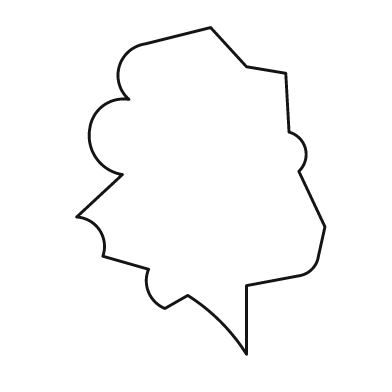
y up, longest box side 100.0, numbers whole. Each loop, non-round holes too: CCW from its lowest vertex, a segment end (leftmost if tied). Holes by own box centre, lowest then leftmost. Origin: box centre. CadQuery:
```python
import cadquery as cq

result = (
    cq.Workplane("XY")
    .moveTo(14.0, -50.0)
    .lineTo(14.0, -29.0)
    .lineTo(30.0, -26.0)
    .threePointArc((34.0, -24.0), (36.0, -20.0))
    .lineTo(38.0, -11.0)
    .lineTo(30.0, 6.0)
    .threePointArc((32.0, 13.0), (27.0, 18.0))
    .lineTo(26.0, 36.0)
    .lineTo(14.0, 38.0)
    .lineTo(3.0, 50.0)
    .lineTo(-17.0, 45.0)
    .threePointArc((-25.0, 38.0), (-22.0, 28.0))
    .threePointArc((-30.0, 26.0), (-34.0, 19.0))
    .threePointArc((-32.0, 10.0), (-24.0, 5.0))
    .lineTo(-38.0, -8.0)
    .threePointArc((-31.0, -12.0), (-30.0, -20.0))
    .lineTo(-16.0, -24.0)
    .threePointArc((-16.0, -31.0), (-11.0, -36.0))
    .lineTo(-4.0, -32.0)
    .threePointArc((6.0, -40.0), (14.0, -50.0))
    .close()
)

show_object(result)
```